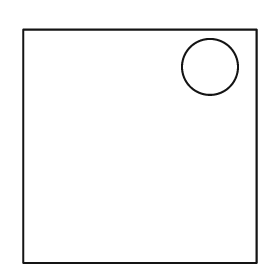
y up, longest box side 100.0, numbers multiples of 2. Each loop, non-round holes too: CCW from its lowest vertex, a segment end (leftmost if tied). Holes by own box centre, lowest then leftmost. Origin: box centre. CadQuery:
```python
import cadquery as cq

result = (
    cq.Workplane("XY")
    .moveTo(-50.0, -50.0)
    .lineTo(50.0, -50.0)
    .lineTo(50.0, 50.0)
    .lineTo(-50.0, 50.0)
    .close()
    .moveTo(30.0, 34.0)
    .circle(12.0)
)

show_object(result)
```